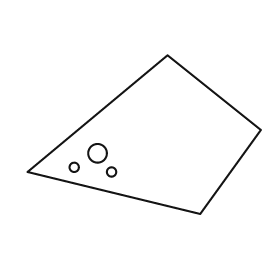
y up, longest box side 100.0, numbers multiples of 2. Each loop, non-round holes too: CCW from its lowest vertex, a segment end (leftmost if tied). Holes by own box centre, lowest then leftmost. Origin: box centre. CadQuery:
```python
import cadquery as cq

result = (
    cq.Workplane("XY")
    .moveTo(24.0, -34.0)
    .lineTo(50.0, 2.0)
    .lineTo(10.0, 34.0)
    .lineTo(-50.0, -16.0)
    .close()
    .moveTo(-14.0, -16.0)
    .circle(2.0)
    .moveTo(-30.0, -14.0)
    .circle(2.0)
    .moveTo(-20.0, -8.0)
    .circle(4.0)
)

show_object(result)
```